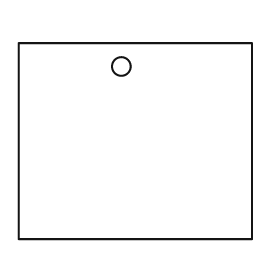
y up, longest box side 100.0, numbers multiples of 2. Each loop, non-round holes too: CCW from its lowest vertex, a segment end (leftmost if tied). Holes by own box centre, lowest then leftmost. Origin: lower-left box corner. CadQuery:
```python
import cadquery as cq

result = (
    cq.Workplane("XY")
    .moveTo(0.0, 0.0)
    .lineTo(100.0, 0.0)
    .lineTo(100.0, 84.0)
    .lineTo(0.0, 84.0)
    .close()
    .moveTo(44.0, 74.0)
    .circle(4.0)
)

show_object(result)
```